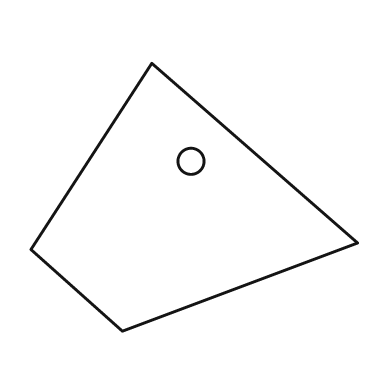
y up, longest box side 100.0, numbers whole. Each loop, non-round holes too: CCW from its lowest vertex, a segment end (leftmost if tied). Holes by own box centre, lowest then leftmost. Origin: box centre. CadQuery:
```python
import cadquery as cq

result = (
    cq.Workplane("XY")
    .moveTo(-22.0, -41.0)
    .lineTo(50.0, -14.0)
    .lineTo(-13.0, 41.0)
    .lineTo(-50.0, -16.0)
    .close()
    .moveTo(-1.0, 11.0)
    .circle(4.0)
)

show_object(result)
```